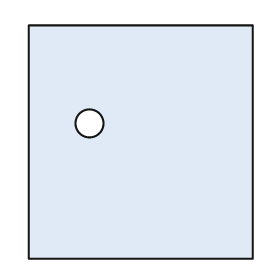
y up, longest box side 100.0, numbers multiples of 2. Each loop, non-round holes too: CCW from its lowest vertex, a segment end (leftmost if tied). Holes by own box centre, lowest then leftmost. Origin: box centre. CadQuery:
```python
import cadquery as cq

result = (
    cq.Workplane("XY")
    .moveTo(-48.0, -50.0)
    .lineTo(48.0, -50.0)
    .lineTo(48.0, 50.0)
    .lineTo(-48.0, 50.0)
    .close()
    .moveTo(-22.0, 8.0)
    .circle(6.0)
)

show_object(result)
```